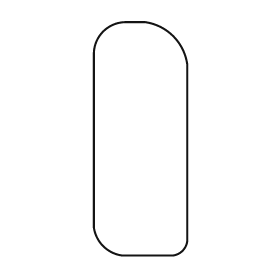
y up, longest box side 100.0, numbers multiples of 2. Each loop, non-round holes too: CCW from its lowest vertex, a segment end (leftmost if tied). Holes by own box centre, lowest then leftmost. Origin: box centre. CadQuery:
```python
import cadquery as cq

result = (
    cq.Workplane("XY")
    .moveTo(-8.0, -50.0)
    .lineTo(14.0, -50.0)
    .threePointArc((18.0, -48.0), (20.0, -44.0))
    .lineTo(20.0, 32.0)
    .threePointArc((14.0, 44.0), (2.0, 50.0))
    .lineTo(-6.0, 50.0)
    .threePointArc((-16.0, 46.0), (-20.0, 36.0))
    .lineTo(-20.0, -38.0)
    .threePointArc((-16.0, -46.0), (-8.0, -50.0))
    .close()
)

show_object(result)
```